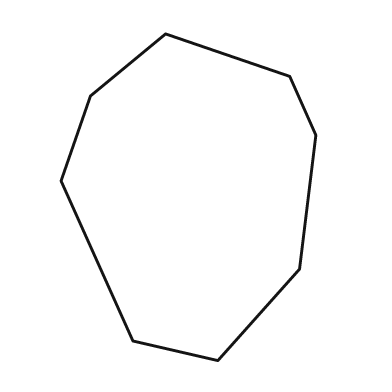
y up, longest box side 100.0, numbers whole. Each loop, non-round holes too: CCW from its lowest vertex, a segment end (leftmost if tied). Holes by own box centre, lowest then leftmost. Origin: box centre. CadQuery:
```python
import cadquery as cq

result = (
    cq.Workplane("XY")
    .moveTo(9.0, -50.0)
    .lineTo(34.0, -22.0)
    .lineTo(39.0, 19.0)
    .lineTo(31.0, 37.0)
    .lineTo(-7.0, 50.0)
    .lineTo(-30.0, 31.0)
    .lineTo(-39.0, 5.0)
    .lineTo(-17.0, -44.0)
    .close()
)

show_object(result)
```